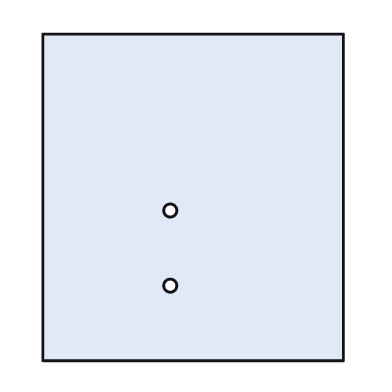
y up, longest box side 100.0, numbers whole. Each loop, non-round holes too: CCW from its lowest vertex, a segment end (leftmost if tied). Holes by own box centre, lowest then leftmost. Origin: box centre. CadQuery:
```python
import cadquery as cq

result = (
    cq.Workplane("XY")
    .moveTo(-46.0, -50.0)
    .lineTo(46.0, -50.0)
    .lineTo(46.0, 50.0)
    .lineTo(-46.0, 50.0)
    .close()
    .moveTo(-7.0, -27.0)
    .circle(2.0)
    .moveTo(-7.0, -4.0)
    .circle(2.0)
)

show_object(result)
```